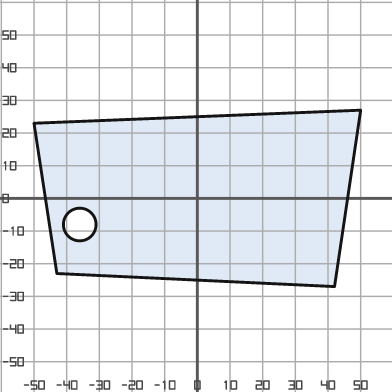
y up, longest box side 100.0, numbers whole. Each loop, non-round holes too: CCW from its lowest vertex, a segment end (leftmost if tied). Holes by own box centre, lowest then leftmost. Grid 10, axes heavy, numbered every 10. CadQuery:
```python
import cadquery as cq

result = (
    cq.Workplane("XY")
    .moveTo(42.0, -27.0)
    .lineTo(50.0, 27.0)
    .lineTo(-50.0, 23.0)
    .lineTo(-43.0, -23.0)
    .close()
    .moveTo(-36.0, -8.0)
    .circle(5.0)
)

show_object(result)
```